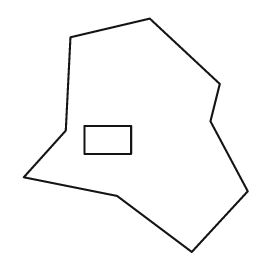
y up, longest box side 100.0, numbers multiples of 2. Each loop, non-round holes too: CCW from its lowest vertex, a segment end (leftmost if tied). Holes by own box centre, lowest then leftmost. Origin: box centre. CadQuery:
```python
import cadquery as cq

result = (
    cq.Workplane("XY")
    .moveTo(24.0, -50.0)
    .lineTo(48.0, -24.0)
    .lineTo(32.0, 6.0)
    .lineTo(36.0, 22.0)
    .lineTo(6.0, 50.0)
    .lineTo(-28.0, 42.0)
    .lineTo(-30.0, 2.0)
    .lineTo(-48.0, -18.0)
    .lineTo(-8.0, -26.0)
    .close()
    .moveTo(-22.0, -8.0)
    .lineTo(-2.0, -8.0)
    .lineTo(-2.0, 4.0)
    .lineTo(-22.0, 4.0)
    .close()
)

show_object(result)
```